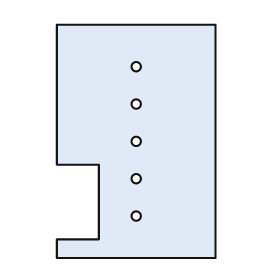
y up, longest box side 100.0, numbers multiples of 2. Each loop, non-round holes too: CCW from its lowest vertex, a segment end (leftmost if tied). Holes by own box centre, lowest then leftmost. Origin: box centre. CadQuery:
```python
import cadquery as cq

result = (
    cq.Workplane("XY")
    .moveTo(-34.0, -50.0)
    .lineTo(34.0, -50.0)
    .lineTo(34.0, 50.0)
    .lineTo(-34.0, 50.0)
    .lineTo(-34.0, -10.0)
    .lineTo(-16.0, -10.0)
    .lineTo(-16.0, -42.0)
    .lineTo(-34.0, -42.0)
    .close()
    .moveTo(0.0, -32.0)
    .circle(2.0)
    .moveTo(0.0, -16.0)
    .circle(2.0)
    .moveTo(0.0, 0.0)
    .circle(2.0)
    .moveTo(0.0, 16.0)
    .circle(2.0)
    .moveTo(0.0, 32.0)
    .circle(2.0)
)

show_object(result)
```